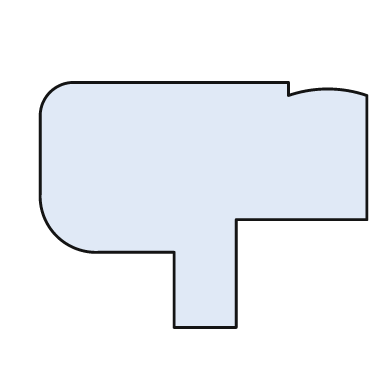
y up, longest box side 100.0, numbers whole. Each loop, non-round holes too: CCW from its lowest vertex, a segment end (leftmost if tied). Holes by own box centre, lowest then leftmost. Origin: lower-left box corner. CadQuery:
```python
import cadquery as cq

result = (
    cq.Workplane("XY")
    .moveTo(41.0, 0.0)
    .lineTo(60.0, 0.0)
    .lineTo(60.0, 33.0)
    .lineTo(100.0, 33.0)
    .lineTo(100.0, 71.0)
    .threePointArc((88.0, 73.0), (76.0, 71.0))
    .lineTo(76.0, 75.0)
    .lineTo(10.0, 75.0)
    .threePointArc((3.0, 72.0), (0.0, 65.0))
    .lineTo(0.0, 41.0)
    .threePointArc((5.0, 28.0), (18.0, 23.0))
    .lineTo(41.0, 23.0)
    .close()
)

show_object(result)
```